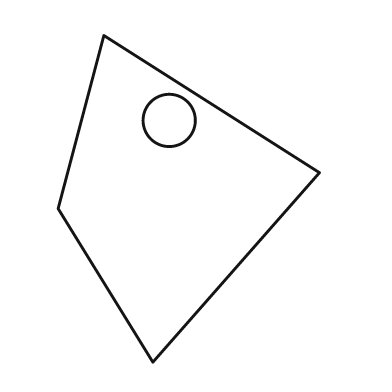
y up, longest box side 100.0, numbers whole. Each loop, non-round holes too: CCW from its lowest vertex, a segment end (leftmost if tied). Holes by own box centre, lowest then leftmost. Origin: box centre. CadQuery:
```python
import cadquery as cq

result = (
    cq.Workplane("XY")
    .moveTo(-11.0, -50.0)
    .lineTo(40.0, 8.0)
    .lineTo(-26.0, 50.0)
    .lineTo(-40.0, -3.0)
    .close()
    .moveTo(-6.0, 24.0)
    .circle(8.0)
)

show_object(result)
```